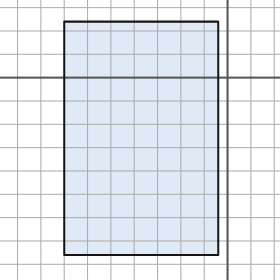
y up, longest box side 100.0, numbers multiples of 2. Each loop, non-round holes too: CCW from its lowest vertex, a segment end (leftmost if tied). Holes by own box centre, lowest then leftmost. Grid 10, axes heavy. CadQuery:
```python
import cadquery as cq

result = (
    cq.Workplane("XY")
    .moveTo(-70.0, -76.0)
    .lineTo(-4.0, -76.0)
    .lineTo(-4.0, 24.0)
    .lineTo(-70.0, 24.0)
    .close()
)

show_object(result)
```